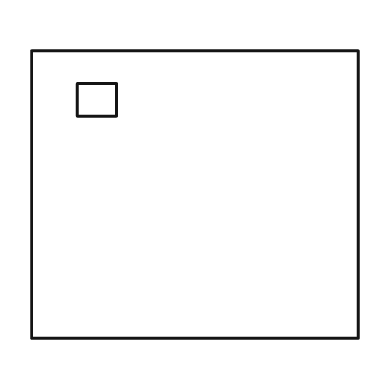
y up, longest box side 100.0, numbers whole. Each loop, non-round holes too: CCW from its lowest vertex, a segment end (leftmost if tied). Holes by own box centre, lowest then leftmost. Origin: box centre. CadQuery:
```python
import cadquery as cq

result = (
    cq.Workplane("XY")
    .moveTo(-50.0, -44.0)
    .lineTo(50.0, -44.0)
    .lineTo(50.0, 44.0)
    .lineTo(-50.0, 44.0)
    .close()
    .moveTo(-36.0, 24.0)
    .lineTo(-24.0, 24.0)
    .lineTo(-24.0, 34.0)
    .lineTo(-36.0, 34.0)
    .close()
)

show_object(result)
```